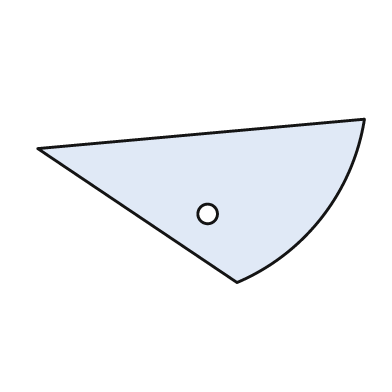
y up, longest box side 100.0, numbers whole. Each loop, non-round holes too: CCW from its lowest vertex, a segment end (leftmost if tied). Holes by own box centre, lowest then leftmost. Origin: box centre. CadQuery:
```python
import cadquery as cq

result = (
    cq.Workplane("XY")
    .moveTo(11.0, -25.0)
    .threePointArc((37.0, -5.0), (50.0, 25.0))
    .lineTo(-50.0, 16.0)
    .close()
    .moveTo(2.0, -4.0)
    .circle(3.0)
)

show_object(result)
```